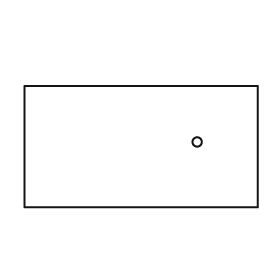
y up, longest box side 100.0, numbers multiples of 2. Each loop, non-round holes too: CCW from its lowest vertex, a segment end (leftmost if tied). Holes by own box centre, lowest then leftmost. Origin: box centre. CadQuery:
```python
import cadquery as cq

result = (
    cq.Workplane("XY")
    .moveTo(-50.0, -26.0)
    .lineTo(50.0, -26.0)
    .lineTo(50.0, 26.0)
    .lineTo(-50.0, 26.0)
    .close()
    .moveTo(24.0, 2.0)
    .circle(2.0)
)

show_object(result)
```